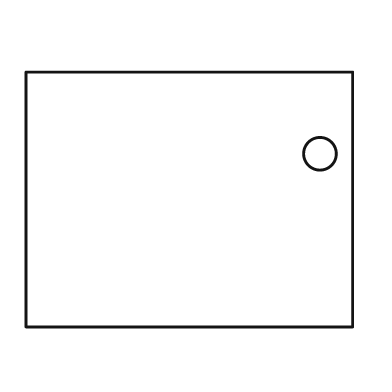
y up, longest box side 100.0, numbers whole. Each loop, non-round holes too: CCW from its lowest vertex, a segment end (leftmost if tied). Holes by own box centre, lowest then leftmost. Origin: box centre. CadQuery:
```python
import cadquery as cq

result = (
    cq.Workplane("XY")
    .moveTo(-50.0, -39.0)
    .lineTo(50.0, -39.0)
    .lineTo(50.0, 39.0)
    .lineTo(-50.0, 39.0)
    .close()
    .moveTo(40.0, 14.0)
    .circle(5.0)
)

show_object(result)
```